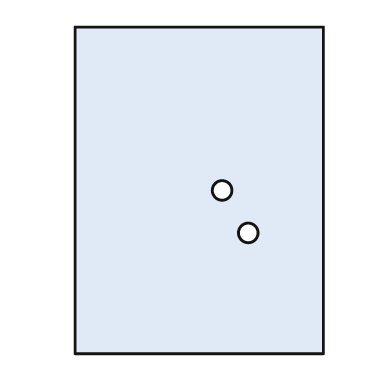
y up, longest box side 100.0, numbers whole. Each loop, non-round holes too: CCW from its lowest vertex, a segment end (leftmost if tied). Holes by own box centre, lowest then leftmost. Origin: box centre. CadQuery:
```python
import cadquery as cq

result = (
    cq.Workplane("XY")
    .moveTo(-38.0, -50.0)
    .lineTo(38.0, -50.0)
    .lineTo(38.0, 50.0)
    .lineTo(-38.0, 50.0)
    .close()
    .moveTo(15.0, -13.0)
    .circle(3.0)
    .moveTo(7.0, 0.0)
    .circle(3.0)
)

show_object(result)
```